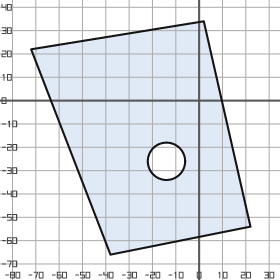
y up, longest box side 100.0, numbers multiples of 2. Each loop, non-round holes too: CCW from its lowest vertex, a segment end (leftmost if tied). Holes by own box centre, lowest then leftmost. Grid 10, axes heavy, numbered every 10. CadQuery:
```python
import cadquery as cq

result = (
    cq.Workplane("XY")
    .moveTo(-38.0, -66.0)
    .lineTo(22.0, -54.0)
    .lineTo(2.0, 34.0)
    .lineTo(-72.0, 22.0)
    .close()
    .moveTo(-14.0, -26.0)
    .circle(8.0)
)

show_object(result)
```